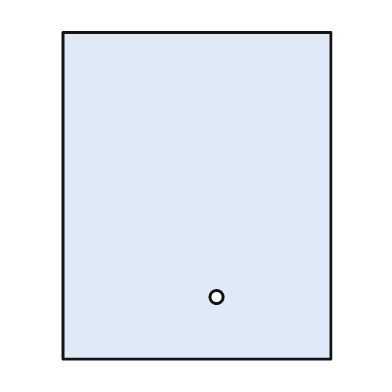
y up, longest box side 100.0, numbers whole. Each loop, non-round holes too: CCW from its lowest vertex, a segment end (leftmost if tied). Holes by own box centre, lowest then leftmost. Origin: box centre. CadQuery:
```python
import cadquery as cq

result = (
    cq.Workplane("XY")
    .moveTo(-41.0, -50.0)
    .lineTo(41.0, -50.0)
    .lineTo(41.0, 50.0)
    .lineTo(-41.0, 50.0)
    .close()
    .moveTo(6.0, -31.0)
    .circle(2.0)
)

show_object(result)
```